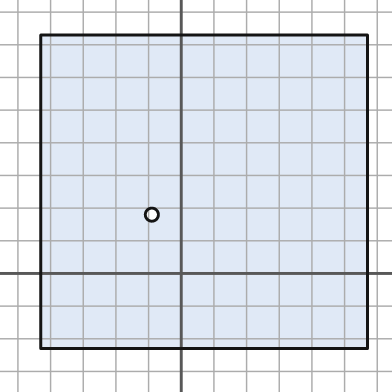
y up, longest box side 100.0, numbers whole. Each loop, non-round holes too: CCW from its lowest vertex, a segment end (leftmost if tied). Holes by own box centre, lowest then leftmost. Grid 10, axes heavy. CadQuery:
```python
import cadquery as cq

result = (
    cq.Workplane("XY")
    .moveTo(-43.0, -23.0)
    .lineTo(57.0, -23.0)
    .lineTo(57.0, 73.0)
    .lineTo(-43.0, 73.0)
    .close()
    .moveTo(-9.0, 18.0)
    .circle(2.0)
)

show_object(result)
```